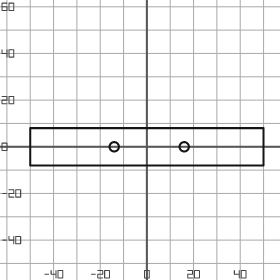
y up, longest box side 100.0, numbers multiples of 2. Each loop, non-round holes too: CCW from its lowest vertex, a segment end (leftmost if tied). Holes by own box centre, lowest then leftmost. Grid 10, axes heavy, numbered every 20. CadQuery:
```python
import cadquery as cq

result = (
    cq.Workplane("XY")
    .moveTo(-50.0, -8.0)
    .lineTo(50.0, -8.0)
    .lineTo(50.0, 8.0)
    .lineTo(-50.0, 8.0)
    .close()
    .moveTo(-14.0, 0.0)
    .circle(2.0)
    .moveTo(16.0, 0.0)
    .circle(2.0)
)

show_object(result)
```